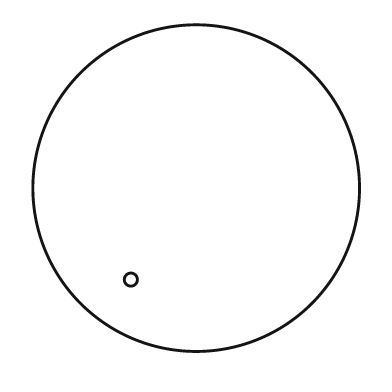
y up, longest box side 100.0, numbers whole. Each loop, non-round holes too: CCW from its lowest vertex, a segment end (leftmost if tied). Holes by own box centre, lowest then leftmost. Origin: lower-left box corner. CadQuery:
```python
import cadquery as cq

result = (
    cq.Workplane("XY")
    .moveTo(50.0, 50.0)
    .circle(50.0)
    .moveTo(30.0, 22.0)
    .circle(2.0)
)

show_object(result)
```